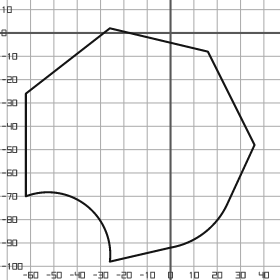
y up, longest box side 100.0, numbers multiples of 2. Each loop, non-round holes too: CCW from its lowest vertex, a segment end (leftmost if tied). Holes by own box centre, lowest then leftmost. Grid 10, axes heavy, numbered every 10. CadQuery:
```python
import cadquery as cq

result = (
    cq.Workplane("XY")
    .moveTo(-26.0, -98.0)
    .lineTo(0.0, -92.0)
    .threePointArc((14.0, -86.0), (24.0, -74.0))
    .lineTo(36.0, -48.0)
    .lineTo(16.0, -8.0)
    .lineTo(-26.0, 2.0)
    .lineTo(-62.0, -26.0)
    .lineTo(-62.0, -70.0)
    .threePointArc((-36.0, -74.0), (-26.0, -98.0))
    .close()
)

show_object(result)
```